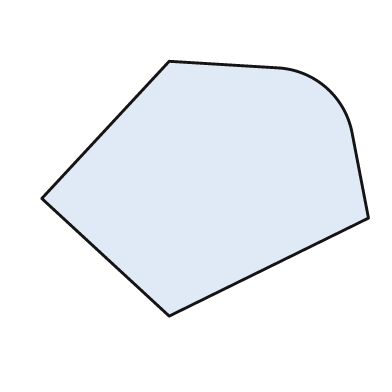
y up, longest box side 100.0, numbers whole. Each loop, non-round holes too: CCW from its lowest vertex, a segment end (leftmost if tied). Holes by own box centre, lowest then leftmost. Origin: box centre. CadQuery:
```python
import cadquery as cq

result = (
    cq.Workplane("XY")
    .moveTo(-11.0, -39.0)
    .lineTo(50.0, -9.0)
    .lineTo(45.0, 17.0)
    .threePointArc((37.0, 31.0), (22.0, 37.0))
    .lineTo(-11.0, 39.0)
    .lineTo(-50.0, -3.0)
    .close()
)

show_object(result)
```